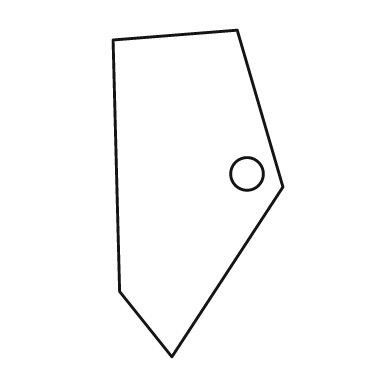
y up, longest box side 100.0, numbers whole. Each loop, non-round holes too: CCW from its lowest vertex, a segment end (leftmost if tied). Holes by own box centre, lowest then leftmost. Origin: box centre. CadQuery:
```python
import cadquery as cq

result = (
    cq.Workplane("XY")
    .moveTo(-8.0, -50.0)
    .lineTo(26.0, 2.0)
    .lineTo(12.0, 50.0)
    .lineTo(-26.0, 47.0)
    .lineTo(-24.0, -30.0)
    .close()
    .moveTo(15.0, 6.0)
    .circle(5.0)
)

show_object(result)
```